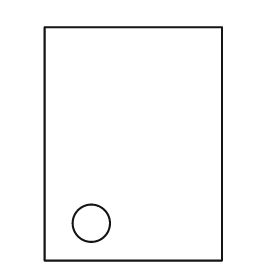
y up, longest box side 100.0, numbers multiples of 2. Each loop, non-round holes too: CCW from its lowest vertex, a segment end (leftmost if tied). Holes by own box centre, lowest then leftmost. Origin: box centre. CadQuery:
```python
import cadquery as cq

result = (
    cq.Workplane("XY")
    .moveTo(-38.0, -50.0)
    .lineTo(38.0, -50.0)
    .lineTo(38.0, 50.0)
    .lineTo(-38.0, 50.0)
    .close()
    .moveTo(-18.0, -34.0)
    .circle(8.0)
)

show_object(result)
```